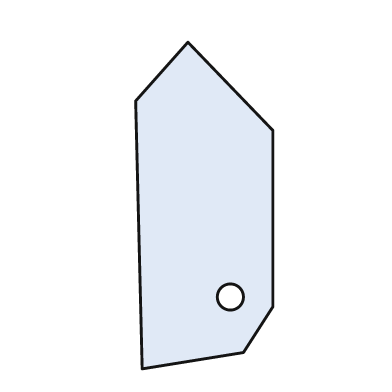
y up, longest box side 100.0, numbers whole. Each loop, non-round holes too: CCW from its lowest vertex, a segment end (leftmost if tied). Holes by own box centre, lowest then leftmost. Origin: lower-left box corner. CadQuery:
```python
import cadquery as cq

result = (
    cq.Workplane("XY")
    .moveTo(2.0, 0.0)
    .lineTo(33.0, 5.0)
    .lineTo(42.0, 19.0)
    .lineTo(42.0, 73.0)
    .lineTo(16.0, 100.0)
    .lineTo(0.0, 82.0)
    .close()
    .moveTo(29.0, 22.0)
    .circle(4.0)
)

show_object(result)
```